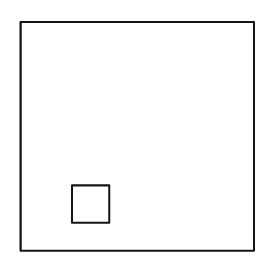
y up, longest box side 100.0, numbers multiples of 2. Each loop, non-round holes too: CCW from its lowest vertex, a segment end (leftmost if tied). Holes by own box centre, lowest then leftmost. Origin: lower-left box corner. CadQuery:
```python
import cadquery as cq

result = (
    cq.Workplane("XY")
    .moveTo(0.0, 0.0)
    .lineTo(100.0, 0.0)
    .lineTo(100.0, 98.0)
    .lineTo(0.0, 98.0)
    .close()
    .moveTo(22.0, 12.0)
    .lineTo(38.0, 12.0)
    .lineTo(38.0, 28.0)
    .lineTo(22.0, 28.0)
    .close()
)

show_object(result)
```